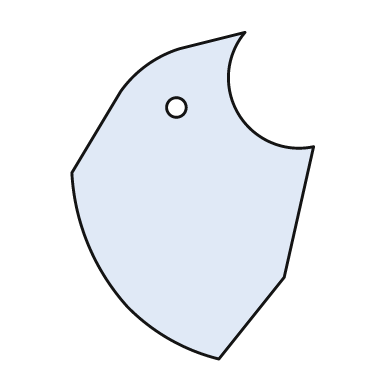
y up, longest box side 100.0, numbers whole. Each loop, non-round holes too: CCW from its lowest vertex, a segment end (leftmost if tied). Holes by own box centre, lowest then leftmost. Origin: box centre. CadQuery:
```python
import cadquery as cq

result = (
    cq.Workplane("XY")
    .moveTo(8.0, -50.0)
    .lineTo(28.0, -25.0)
    .lineTo(37.0, 15.0)
    .threePointArc((14.0, 25.0), (16.0, 50.0))
    .lineTo(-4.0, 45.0)
    .threePointArc((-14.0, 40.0), (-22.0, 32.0))
    .lineTo(-37.0, 7.0)
    .threePointArc((-32.0, -15.0), (-20.0, -34.0))
    .threePointArc((-7.0, -44.0), (8.0, -50.0))
    .close()
    .moveTo(-5.0, 27.0)
    .circle(3.0)
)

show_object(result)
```